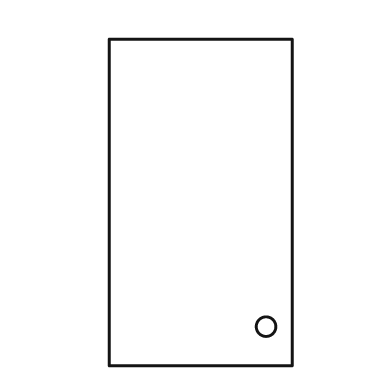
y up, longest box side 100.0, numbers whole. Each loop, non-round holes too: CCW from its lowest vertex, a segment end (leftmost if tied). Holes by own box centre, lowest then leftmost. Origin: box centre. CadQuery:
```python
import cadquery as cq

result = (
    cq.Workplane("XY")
    .moveTo(-28.0, -50.0)
    .lineTo(28.0, -50.0)
    .lineTo(28.0, 50.0)
    .lineTo(-28.0, 50.0)
    .close()
    .moveTo(20.0, -38.0)
    .circle(3.0)
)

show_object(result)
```